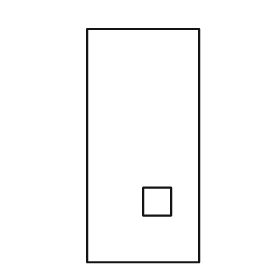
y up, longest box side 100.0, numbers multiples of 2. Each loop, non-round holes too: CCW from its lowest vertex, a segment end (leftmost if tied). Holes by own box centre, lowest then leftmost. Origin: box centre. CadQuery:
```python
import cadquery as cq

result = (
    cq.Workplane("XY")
    .moveTo(-24.0, -50.0)
    .lineTo(24.0, -50.0)
    .lineTo(24.0, 50.0)
    .lineTo(-24.0, 50.0)
    .close()
    .moveTo(0.0, -30.0)
    .lineTo(12.0, -30.0)
    .lineTo(12.0, -18.0)
    .lineTo(0.0, -18.0)
    .close()
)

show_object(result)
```